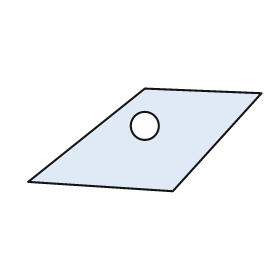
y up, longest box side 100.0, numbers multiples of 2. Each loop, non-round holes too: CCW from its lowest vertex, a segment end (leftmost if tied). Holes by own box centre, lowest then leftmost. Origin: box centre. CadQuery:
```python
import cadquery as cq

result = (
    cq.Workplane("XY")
    .moveTo(12.0, -22.0)
    .lineTo(50.0, 20.0)
    .lineTo(0.0, 22.0)
    .lineTo(-50.0, -18.0)
    .close()
    .moveTo(0.0, 6.0)
    .circle(6.0)
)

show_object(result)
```